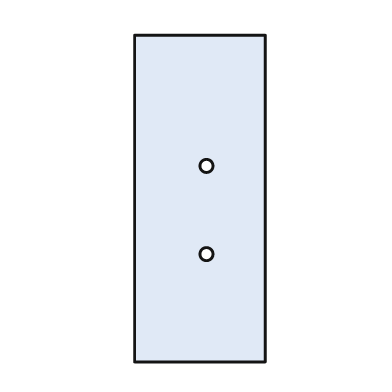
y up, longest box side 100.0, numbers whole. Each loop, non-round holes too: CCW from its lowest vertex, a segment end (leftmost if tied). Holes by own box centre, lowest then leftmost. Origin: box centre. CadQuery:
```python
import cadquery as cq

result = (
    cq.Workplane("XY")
    .moveTo(-20.0, -50.0)
    .lineTo(20.0, -50.0)
    .lineTo(20.0, 50.0)
    .lineTo(-20.0, 50.0)
    .close()
    .moveTo(2.0, -17.0)
    .circle(2.0)
    .moveTo(2.0, 10.0)
    .circle(2.0)
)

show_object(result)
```